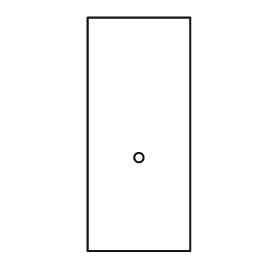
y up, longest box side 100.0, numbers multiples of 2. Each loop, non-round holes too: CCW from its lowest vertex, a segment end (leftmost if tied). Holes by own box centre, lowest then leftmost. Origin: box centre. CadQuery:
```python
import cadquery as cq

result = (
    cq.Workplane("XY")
    .moveTo(-22.0, -50.0)
    .lineTo(22.0, -50.0)
    .lineTo(22.0, 50.0)
    .lineTo(-22.0, 50.0)
    .close()
    .moveTo(0.0, -10.0)
    .circle(2.0)
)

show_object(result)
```